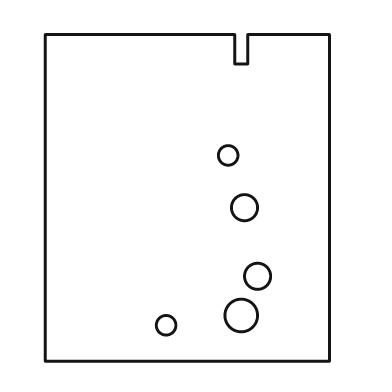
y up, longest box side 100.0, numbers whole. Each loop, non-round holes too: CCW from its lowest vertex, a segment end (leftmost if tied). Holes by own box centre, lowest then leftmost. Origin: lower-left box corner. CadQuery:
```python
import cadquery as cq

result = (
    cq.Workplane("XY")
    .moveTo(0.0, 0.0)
    .lineTo(87.0, 0.0)
    .lineTo(87.0, 100.0)
    .lineTo(62.0, 100.0)
    .lineTo(62.0, 91.0)
    .lineTo(58.0, 91.0)
    .lineTo(58.0, 100.0)
    .lineTo(0.0, 100.0)
    .close()
    .moveTo(37.0, 11.0)
    .circle(3.0)
    .moveTo(60.0, 14.0)
    .circle(5.0)
    .moveTo(65.0, 26.0)
    .circle(4.0)
    .moveTo(61.0, 47.0)
    .circle(4.0)
    .moveTo(56.0, 63.0)
    .circle(3.0)
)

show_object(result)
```